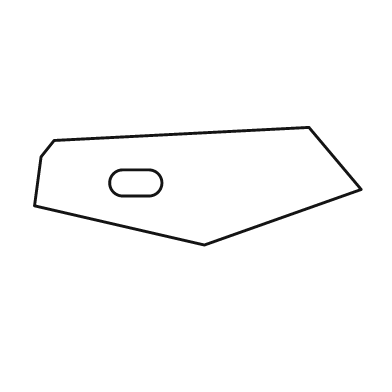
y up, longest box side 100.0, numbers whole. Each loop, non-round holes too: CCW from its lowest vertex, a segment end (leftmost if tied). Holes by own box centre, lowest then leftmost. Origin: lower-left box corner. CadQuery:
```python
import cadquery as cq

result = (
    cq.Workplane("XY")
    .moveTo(52.0, 0.0)
    .lineTo(100.0, 17.0)
    .lineTo(84.0, 36.0)
    .lineTo(6.0, 32.0)
    .lineTo(2.0, 27.0)
    .lineTo(0.0, 12.0)
    .close()
    .moveTo(27.0, 15.0)
    .lineTo(35.0, 15.0)
    .threePointArc((39.0, 19.0), (35.0, 23.0))
    .lineTo(27.0, 23.0)
    .threePointArc((23.0, 19.0), (27.0, 15.0))
    .close()
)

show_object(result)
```